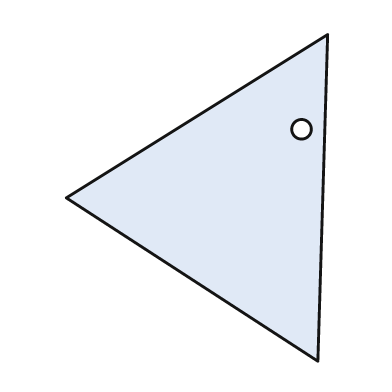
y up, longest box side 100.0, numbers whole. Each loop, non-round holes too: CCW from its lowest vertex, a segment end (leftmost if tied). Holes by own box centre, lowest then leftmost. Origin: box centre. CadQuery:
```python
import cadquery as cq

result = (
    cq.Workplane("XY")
    .moveTo(37.0, -50.0)
    .lineTo(40.0, 50.0)
    .lineTo(-40.0, 0.0)
    .close()
    .moveTo(32.0, 21.0)
    .circle(3.0)
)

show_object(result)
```